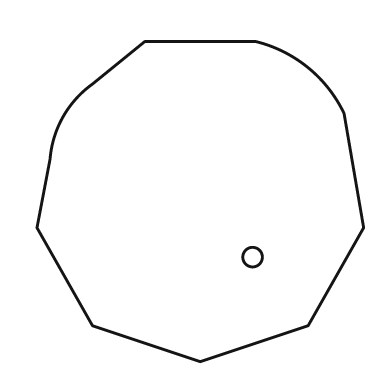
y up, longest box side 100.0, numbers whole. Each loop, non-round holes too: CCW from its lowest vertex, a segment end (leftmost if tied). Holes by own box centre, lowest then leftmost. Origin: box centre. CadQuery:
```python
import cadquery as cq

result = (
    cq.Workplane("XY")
    .moveTo(0.0, -49.0)
    .lineTo(33.0, -38.0)
    .lineTo(50.0, -8.0)
    .lineTo(44.0, 27.0)
    .threePointArc((33.0, 41.0), (17.0, 49.0))
    .lineTo(-17.0, 49.0)
    .lineTo(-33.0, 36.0)
    .threePointArc((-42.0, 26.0), (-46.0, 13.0))
    .lineTo(-50.0, -8.0)
    .lineTo(-33.0, -38.0)
    .close()
    .moveTo(16.0, -17.0)
    .circle(3.0)
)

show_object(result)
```